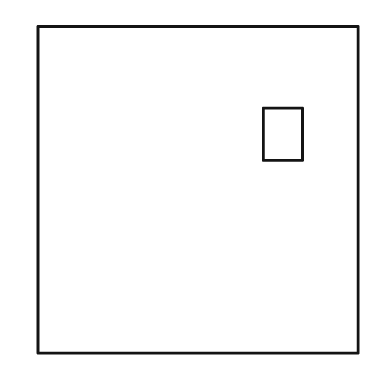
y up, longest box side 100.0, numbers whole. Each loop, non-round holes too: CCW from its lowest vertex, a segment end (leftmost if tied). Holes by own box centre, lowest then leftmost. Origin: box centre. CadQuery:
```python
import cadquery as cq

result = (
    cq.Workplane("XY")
    .moveTo(-49.0, -50.0)
    .lineTo(49.0, -50.0)
    .lineTo(49.0, 50.0)
    .lineTo(-49.0, 50.0)
    .close()
    .moveTo(20.0, 9.0)
    .lineTo(32.0, 9.0)
    .lineTo(32.0, 25.0)
    .lineTo(20.0, 25.0)
    .close()
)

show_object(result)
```